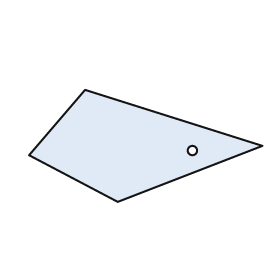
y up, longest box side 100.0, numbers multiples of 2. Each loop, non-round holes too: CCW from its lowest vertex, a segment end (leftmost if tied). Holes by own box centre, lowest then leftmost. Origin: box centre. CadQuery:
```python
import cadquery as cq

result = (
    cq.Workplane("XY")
    .moveTo(-12.0, -24.0)
    .lineTo(50.0, 0.0)
    .lineTo(-26.0, 24.0)
    .lineTo(-50.0, -4.0)
    .close()
    .moveTo(20.0, -2.0)
    .circle(2.0)
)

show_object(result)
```